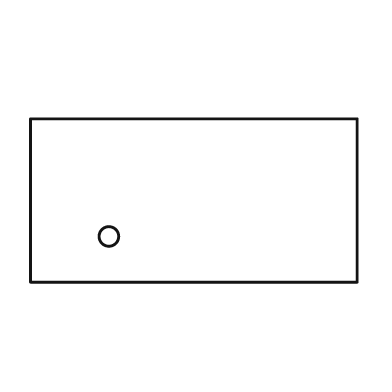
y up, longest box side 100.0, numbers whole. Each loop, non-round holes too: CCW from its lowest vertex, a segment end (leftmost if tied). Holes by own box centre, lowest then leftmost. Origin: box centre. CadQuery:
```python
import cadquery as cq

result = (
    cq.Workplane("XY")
    .moveTo(-50.0, -25.0)
    .lineTo(50.0, -25.0)
    .lineTo(50.0, 25.0)
    .lineTo(-50.0, 25.0)
    .close()
    .moveTo(-26.0, -11.0)
    .circle(3.0)
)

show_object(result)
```